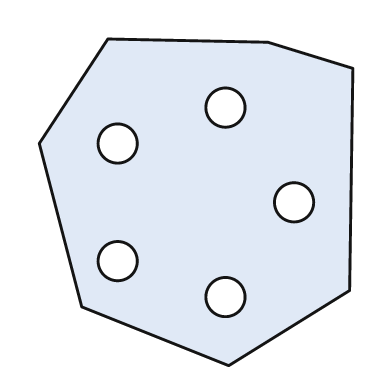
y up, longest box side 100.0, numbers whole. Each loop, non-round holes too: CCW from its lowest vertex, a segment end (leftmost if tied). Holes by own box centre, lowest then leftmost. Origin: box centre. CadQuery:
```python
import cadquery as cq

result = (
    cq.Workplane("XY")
    .moveTo(10.0, -50.0)
    .lineTo(47.0, -27.0)
    .lineTo(48.0, 41.0)
    .lineTo(22.0, 49.0)
    .lineTo(-27.0, 50.0)
    .lineTo(-48.0, 18.0)
    .lineTo(-35.0, -32.0)
    .close()
    .moveTo(9.0, -29.0)
    .circle(6.0)
    .moveTo(-24.0, -18.0)
    .circle(6.0)
    .moveTo(30.0, 0.0)
    .circle(6.0)
    .moveTo(-24.0, 18.0)
    .circle(6.0)
    .moveTo(9.0, 29.0)
    .circle(6.0)
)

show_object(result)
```